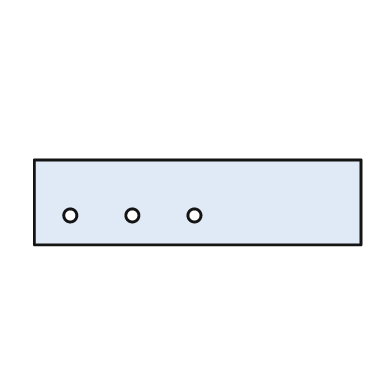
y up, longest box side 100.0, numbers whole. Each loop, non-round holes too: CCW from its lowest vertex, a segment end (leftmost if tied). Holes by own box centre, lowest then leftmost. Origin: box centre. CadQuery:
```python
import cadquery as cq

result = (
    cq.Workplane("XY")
    .moveTo(-50.0, -13.0)
    .lineTo(50.0, -13.0)
    .lineTo(50.0, 13.0)
    .lineTo(-50.0, 13.0)
    .close()
    .moveTo(-39.0, -4.0)
    .circle(2.0)
    .moveTo(-20.0, -4.0)
    .circle(2.0)
    .moveTo(-1.0, -4.0)
    .circle(2.0)
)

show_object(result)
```